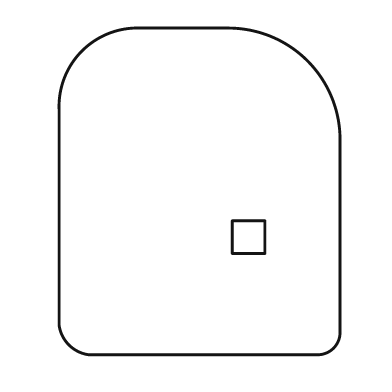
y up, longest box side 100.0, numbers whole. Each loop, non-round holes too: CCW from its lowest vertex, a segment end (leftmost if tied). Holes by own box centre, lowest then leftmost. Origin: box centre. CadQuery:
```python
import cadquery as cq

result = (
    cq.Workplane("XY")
    .moveTo(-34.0, -50.0)
    .lineTo(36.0, -50.0)
    .threePointArc((41.0, -48.0), (43.0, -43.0))
    .lineTo(43.0, 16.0)
    .threePointArc((33.0, 40.0), (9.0, 50.0))
    .lineTo(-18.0, 50.0)
    .threePointArc((-36.0, 43.0), (-43.0, 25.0))
    .lineTo(-43.0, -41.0)
    .threePointArc((-40.0, -47.0), (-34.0, -50.0))
    .close()
    .moveTo(10.0, -19.0)
    .lineTo(20.0, -19.0)
    .lineTo(20.0, -9.0)
    .lineTo(10.0, -9.0)
    .close()
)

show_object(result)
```